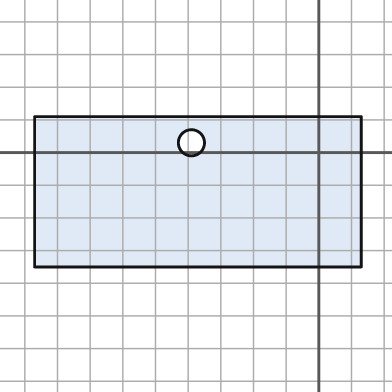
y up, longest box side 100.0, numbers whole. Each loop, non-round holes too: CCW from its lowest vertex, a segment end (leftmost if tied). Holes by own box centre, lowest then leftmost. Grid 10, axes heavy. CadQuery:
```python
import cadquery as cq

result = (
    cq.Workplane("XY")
    .moveTo(-87.0, -35.0)
    .lineTo(13.0, -35.0)
    .lineTo(13.0, 11.0)
    .lineTo(-87.0, 11.0)
    .close()
    .moveTo(-39.0, 3.0)
    .circle(4.0)
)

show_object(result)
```